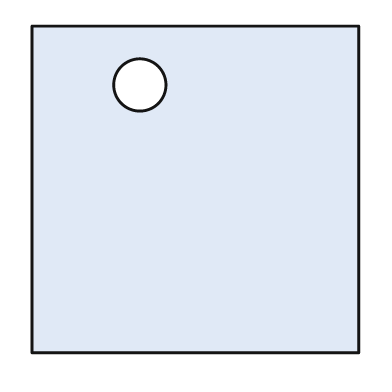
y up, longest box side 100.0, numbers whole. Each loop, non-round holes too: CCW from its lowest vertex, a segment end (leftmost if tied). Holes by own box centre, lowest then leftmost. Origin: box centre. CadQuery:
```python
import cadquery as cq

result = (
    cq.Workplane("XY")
    .moveTo(-50.0, -50.0)
    .lineTo(50.0, -50.0)
    .lineTo(50.0, 50.0)
    .lineTo(-50.0, 50.0)
    .close()
    .moveTo(-17.0, 32.0)
    .circle(8.0)
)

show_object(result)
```